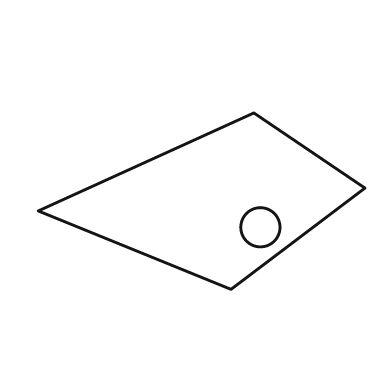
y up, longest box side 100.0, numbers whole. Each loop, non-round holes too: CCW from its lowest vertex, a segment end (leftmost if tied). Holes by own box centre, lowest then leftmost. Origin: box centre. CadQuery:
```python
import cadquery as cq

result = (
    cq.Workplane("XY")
    .moveTo(9.0, -27.0)
    .lineTo(50.0, 4.0)
    .lineTo(16.0, 27.0)
    .lineTo(-50.0, -3.0)
    .close()
    .moveTo(18.0, -8.0)
    .circle(6.0)
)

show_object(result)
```